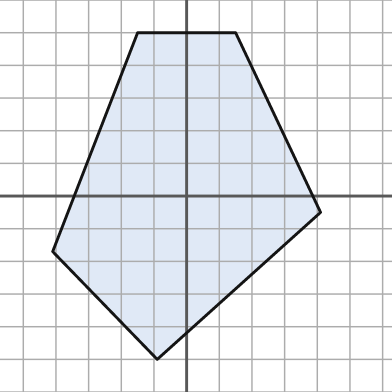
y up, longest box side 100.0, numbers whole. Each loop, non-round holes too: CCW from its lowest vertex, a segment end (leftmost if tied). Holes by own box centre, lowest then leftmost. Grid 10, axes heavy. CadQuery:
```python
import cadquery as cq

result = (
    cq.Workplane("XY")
    .moveTo(-9.0, -50.0)
    .lineTo(41.0, -5.0)
    .lineTo(15.0, 50.0)
    .lineTo(-15.0, 50.0)
    .lineTo(-41.0, -17.0)
    .close()
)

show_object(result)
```